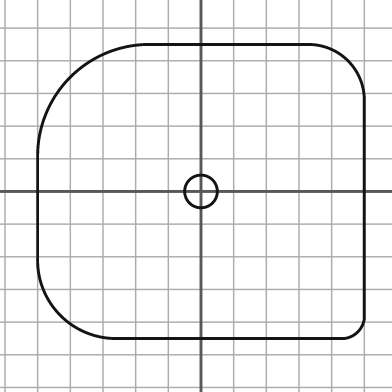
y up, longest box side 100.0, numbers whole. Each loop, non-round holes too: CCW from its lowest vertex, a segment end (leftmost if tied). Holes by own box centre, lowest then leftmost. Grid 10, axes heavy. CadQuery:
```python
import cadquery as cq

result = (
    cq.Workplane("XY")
    .moveTo(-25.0, -45.0)
    .lineTo(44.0, -45.0)
    .threePointArc((48.0, -43.0), (50.0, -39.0))
    .lineTo(50.0, 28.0)
    .threePointArc((45.0, 40.0), (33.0, 45.0))
    .lineTo(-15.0, 45.0)
    .threePointArc((-40.0, 35.0), (-50.0, 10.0))
    .lineTo(-50.0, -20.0)
    .threePointArc((-43.0, -38.0), (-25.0, -45.0))
    .close()
    .moveTo(0.0, 0.0)
    .circle(5.0)
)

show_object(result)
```